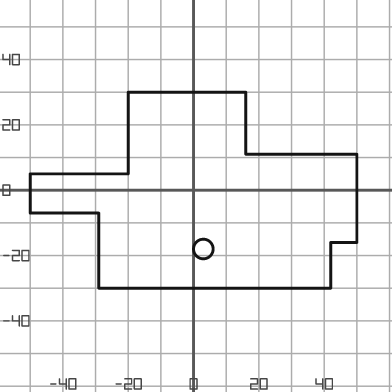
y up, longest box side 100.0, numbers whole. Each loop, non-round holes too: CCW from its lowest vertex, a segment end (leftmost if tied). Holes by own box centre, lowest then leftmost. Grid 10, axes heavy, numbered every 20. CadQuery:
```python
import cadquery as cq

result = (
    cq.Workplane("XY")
    .moveTo(-29.0, -30.0)
    .lineTo(42.0, -30.0)
    .lineTo(42.0, -16.0)
    .lineTo(50.0, -16.0)
    .lineTo(50.0, 11.0)
    .lineTo(16.0, 11.0)
    .lineTo(16.0, 30.0)
    .lineTo(-20.0, 30.0)
    .lineTo(-20.0, 5.0)
    .lineTo(-50.0, 5.0)
    .lineTo(-50.0, -7.0)
    .lineTo(-29.0, -7.0)
    .close()
    .moveTo(3.0, -18.0)
    .circle(3.0)
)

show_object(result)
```